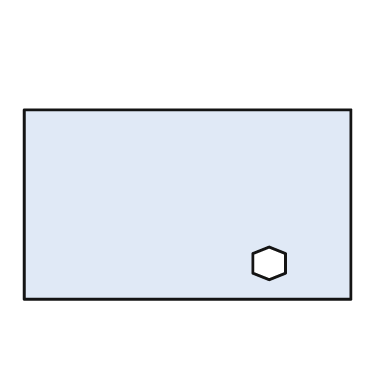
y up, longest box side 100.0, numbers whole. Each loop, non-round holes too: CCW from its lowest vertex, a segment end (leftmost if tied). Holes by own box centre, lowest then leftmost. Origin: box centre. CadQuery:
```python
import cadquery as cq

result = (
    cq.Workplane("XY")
    .moveTo(-50.0, -29.0)
    .lineTo(50.0, -29.0)
    .lineTo(50.0, 29.0)
    .lineTo(-50.0, 29.0)
    .close()
    .moveTo(25.0, -23.0)
    .lineTo(30.0, -21.0)
    .lineTo(30.0, -15.0)
    .lineTo(25.0, -13.0)
    .lineTo(20.0, -15.0)
    .lineTo(20.0, -21.0)
    .close()
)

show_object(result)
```